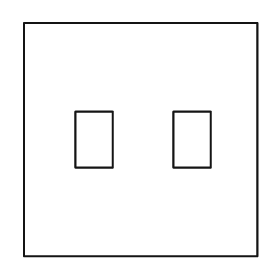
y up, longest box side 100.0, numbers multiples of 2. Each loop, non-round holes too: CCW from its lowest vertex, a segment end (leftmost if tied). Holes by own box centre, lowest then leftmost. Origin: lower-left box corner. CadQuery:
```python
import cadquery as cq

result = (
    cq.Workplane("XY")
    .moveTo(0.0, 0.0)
    .lineTo(100.0, 0.0)
    .lineTo(100.0, 100.0)
    .lineTo(0.0, 100.0)
    .close()
    .moveTo(22.0, 38.0)
    .lineTo(38.0, 38.0)
    .lineTo(38.0, 62.0)
    .lineTo(22.0, 62.0)
    .close()
    .moveTo(64.0, 38.0)
    .lineTo(80.0, 38.0)
    .lineTo(80.0, 62.0)
    .lineTo(64.0, 62.0)
    .close()
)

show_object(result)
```